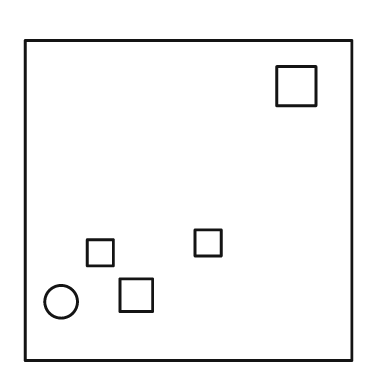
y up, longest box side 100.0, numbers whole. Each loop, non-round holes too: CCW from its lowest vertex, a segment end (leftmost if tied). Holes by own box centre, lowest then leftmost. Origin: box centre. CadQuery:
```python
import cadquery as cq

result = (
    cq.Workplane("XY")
    .moveTo(-50.0, -49.0)
    .lineTo(50.0, -49.0)
    .lineTo(50.0, 49.0)
    .lineTo(-50.0, 49.0)
    .close()
    .moveTo(-39.0, -31.0)
    .circle(5.0)
    .moveTo(-21.0, -34.0)
    .lineTo(-11.0, -34.0)
    .lineTo(-11.0, -24.0)
    .lineTo(-21.0, -24.0)
    .close()
    .moveTo(-31.0, -20.0)
    .lineTo(-23.0, -20.0)
    .lineTo(-23.0, -12.0)
    .lineTo(-31.0, -12.0)
    .close()
    .moveTo(2.0, -17.0)
    .lineTo(10.0, -17.0)
    .lineTo(10.0, -9.0)
    .lineTo(2.0, -9.0)
    .close()
    .moveTo(27.0, 29.0)
    .lineTo(39.0, 29.0)
    .lineTo(39.0, 41.0)
    .lineTo(27.0, 41.0)
    .close()
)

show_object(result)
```